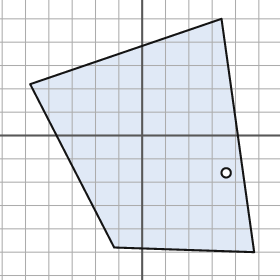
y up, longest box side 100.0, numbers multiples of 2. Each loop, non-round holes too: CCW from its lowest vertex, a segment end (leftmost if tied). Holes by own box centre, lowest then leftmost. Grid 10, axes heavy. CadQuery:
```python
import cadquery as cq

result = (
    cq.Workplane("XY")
    .moveTo(48.0, -50.0)
    .lineTo(34.0, 50.0)
    .lineTo(-48.0, 22.0)
    .lineTo(-12.0, -48.0)
    .close()
    .moveTo(36.0, -16.0)
    .circle(2.0)
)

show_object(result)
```